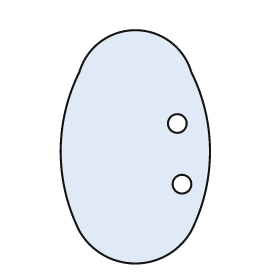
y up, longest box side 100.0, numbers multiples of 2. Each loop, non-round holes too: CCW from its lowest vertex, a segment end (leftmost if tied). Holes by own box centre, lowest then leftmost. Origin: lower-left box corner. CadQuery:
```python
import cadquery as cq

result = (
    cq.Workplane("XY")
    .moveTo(8.0, 14.0)
    .threePointArc((32.0, 0.0), (56.0, 14.0))
    .threePointArc((64.0, 48.0), (56.0, 82.0))
    .threePointArc((32.0, 100.0), (8.0, 82.0))
    .threePointArc((0.0, 48.0), (8.0, 14.0))
    .close()
    .moveTo(52.0, 34.0)
    .circle(4.0)
    .moveTo(50.0, 60.0)
    .circle(4.0)
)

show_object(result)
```